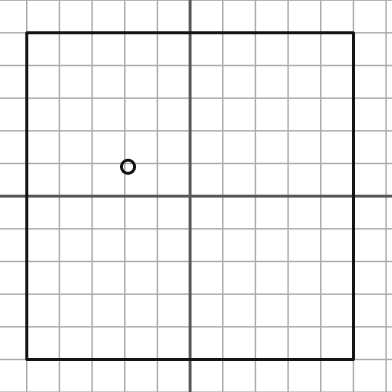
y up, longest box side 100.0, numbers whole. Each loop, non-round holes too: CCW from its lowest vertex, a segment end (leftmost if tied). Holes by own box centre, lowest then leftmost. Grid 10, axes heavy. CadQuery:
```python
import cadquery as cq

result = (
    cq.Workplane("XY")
    .moveTo(-50.0, -50.0)
    .lineTo(50.0, -50.0)
    .lineTo(50.0, 50.0)
    .lineTo(-50.0, 50.0)
    .close()
    .moveTo(-19.0, 9.0)
    .circle(2.0)
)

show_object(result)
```